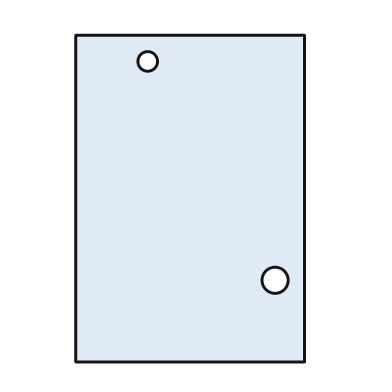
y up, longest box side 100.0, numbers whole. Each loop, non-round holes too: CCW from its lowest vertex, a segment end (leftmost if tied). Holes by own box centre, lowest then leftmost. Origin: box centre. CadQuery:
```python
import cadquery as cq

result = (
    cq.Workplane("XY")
    .moveTo(-35.0, -50.0)
    .lineTo(35.0, -50.0)
    .lineTo(35.0, 50.0)
    .lineTo(-35.0, 50.0)
    .close()
    .moveTo(26.0, -25.0)
    .circle(4.0)
    .moveTo(-13.0, 42.0)
    .circle(3.0)
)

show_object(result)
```